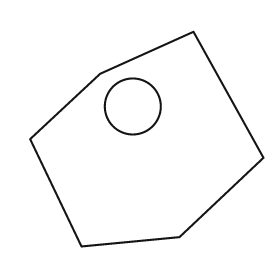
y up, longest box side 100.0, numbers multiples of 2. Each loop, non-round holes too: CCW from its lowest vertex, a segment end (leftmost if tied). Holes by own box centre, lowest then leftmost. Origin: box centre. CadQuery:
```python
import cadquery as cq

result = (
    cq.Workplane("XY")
    .moveTo(-28.0, -46.0)
    .lineTo(14.0, -42.0)
    .lineTo(50.0, -8.0)
    .lineTo(20.0, 46.0)
    .lineTo(-20.0, 28.0)
    .lineTo(-50.0, 0.0)
    .close()
    .moveTo(-6.0, 14.0)
    .circle(12.0)
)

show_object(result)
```